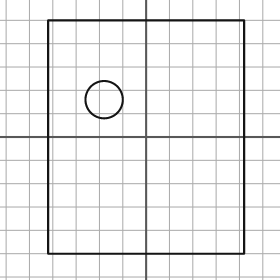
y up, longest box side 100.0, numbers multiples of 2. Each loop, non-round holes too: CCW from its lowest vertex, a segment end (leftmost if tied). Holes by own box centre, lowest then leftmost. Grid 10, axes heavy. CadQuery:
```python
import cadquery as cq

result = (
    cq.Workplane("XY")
    .moveTo(-42.0, -50.0)
    .lineTo(42.0, -50.0)
    .lineTo(42.0, 50.0)
    .lineTo(-42.0, 50.0)
    .close()
    .moveTo(-18.0, 16.0)
    .circle(8.0)
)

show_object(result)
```